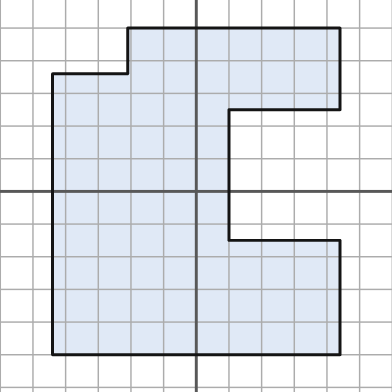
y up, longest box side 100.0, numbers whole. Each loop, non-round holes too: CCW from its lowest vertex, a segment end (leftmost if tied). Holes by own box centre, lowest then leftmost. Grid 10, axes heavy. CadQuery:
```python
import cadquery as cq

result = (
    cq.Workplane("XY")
    .moveTo(-44.0, -50.0)
    .lineTo(44.0, -50.0)
    .lineTo(44.0, -15.0)
    .lineTo(10.0, -15.0)
    .lineTo(10.0, 25.0)
    .lineTo(44.0, 25.0)
    .lineTo(44.0, 50.0)
    .lineTo(-21.0, 50.0)
    .lineTo(-21.0, 36.0)
    .lineTo(-44.0, 36.0)
    .close()
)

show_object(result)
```